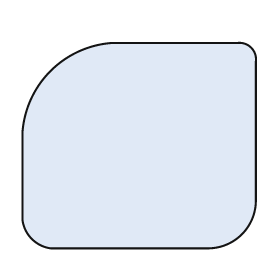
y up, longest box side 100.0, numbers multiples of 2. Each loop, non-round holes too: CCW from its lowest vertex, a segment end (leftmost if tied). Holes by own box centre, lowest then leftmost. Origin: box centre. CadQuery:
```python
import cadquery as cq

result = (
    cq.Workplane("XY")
    .moveTo(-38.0, -44.0)
    .lineTo(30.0, -44.0)
    .threePointArc((44.0, -38.0), (50.0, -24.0))
    .lineTo(50.0, 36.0)
    .threePointArc((48.0, 42.0), (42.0, 44.0))
    .lineTo(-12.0, 44.0)
    .threePointArc((-38.0, 32.0), (-50.0, 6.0))
    .lineTo(-50.0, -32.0)
    .threePointArc((-46.0, -40.0), (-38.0, -44.0))
    .close()
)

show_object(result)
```